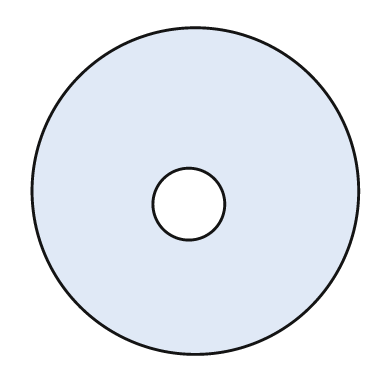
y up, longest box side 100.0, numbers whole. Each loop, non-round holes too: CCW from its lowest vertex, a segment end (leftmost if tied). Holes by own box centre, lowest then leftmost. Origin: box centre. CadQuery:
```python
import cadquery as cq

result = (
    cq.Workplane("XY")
    .moveTo(0.0, 0.0)
    .circle(50.0)
    .moveTo(-2.0, -4.0)
    .circle(11.0)
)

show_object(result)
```